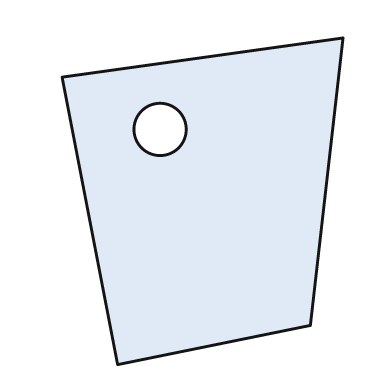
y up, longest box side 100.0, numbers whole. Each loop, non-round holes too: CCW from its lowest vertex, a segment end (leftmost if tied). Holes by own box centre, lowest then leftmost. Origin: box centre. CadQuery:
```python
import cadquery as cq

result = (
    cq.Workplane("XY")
    .moveTo(-26.0, -50.0)
    .lineTo(33.0, -38.0)
    .lineTo(43.0, 50.0)
    .lineTo(-43.0, 38.0)
    .close()
    .moveTo(-13.0, 22.0)
    .circle(8.0)
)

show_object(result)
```